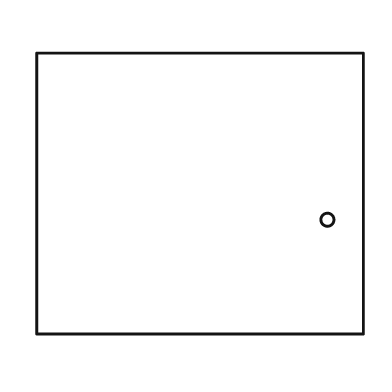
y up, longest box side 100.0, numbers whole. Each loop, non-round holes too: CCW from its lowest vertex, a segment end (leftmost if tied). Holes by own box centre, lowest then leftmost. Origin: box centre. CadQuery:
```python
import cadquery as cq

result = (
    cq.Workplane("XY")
    .moveTo(-50.0, -43.0)
    .lineTo(50.0, -43.0)
    .lineTo(50.0, 43.0)
    .lineTo(-50.0, 43.0)
    .close()
    .moveTo(39.0, -8.0)
    .circle(2.0)
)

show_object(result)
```